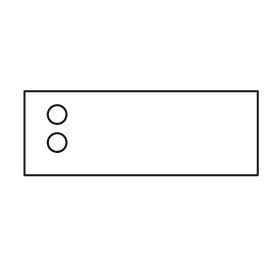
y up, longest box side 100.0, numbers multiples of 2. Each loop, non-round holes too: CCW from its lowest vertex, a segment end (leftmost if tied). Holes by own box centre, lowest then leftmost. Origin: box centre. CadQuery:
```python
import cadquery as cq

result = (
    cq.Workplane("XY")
    .moveTo(-50.0, -18.0)
    .lineTo(50.0, -18.0)
    .lineTo(50.0, 18.0)
    .lineTo(-50.0, 18.0)
    .close()
    .moveTo(-36.0, -4.0)
    .circle(4.0)
    .moveTo(-36.0, 8.0)
    .circle(4.0)
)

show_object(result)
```